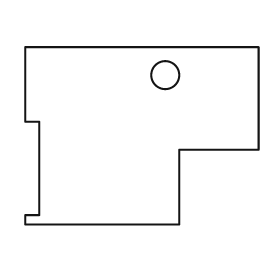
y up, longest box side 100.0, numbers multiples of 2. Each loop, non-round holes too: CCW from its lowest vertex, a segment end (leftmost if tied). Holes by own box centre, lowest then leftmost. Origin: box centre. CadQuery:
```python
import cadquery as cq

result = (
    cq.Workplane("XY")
    .moveTo(-50.0, -38.0)
    .lineTo(16.0, -38.0)
    .lineTo(16.0, -6.0)
    .lineTo(50.0, -6.0)
    .lineTo(50.0, 38.0)
    .lineTo(-50.0, 38.0)
    .lineTo(-50.0, 6.0)
    .lineTo(-44.0, 6.0)
    .lineTo(-44.0, -34.0)
    .lineTo(-50.0, -34.0)
    .close()
    .moveTo(10.0, 26.0)
    .circle(6.0)
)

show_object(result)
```